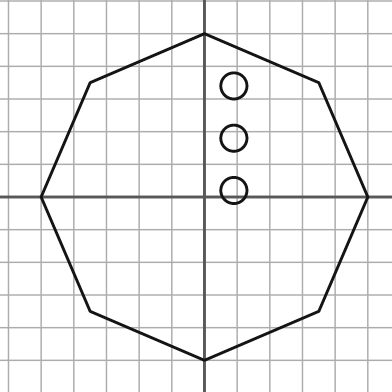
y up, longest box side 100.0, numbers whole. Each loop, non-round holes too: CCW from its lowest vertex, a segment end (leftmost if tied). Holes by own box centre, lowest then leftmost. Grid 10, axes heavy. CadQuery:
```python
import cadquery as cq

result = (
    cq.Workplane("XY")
    .moveTo(0.0, -50.0)
    .lineTo(35.0, -35.0)
    .lineTo(50.0, 0.0)
    .lineTo(35.0, 35.0)
    .lineTo(0.0, 50.0)
    .lineTo(-35.0, 35.0)
    .lineTo(-50.0, 0.0)
    .lineTo(-35.0, -35.0)
    .close()
    .moveTo(9.0, 2.0)
    .circle(4.0)
    .moveTo(9.0, 18.0)
    .circle(4.0)
    .moveTo(9.0, 34.0)
    .circle(4.0)
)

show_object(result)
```